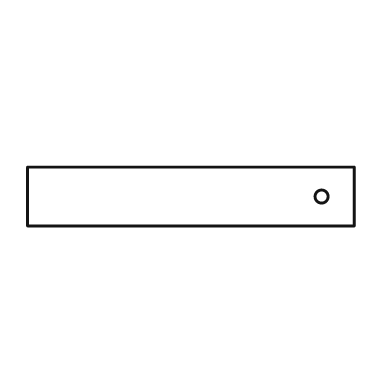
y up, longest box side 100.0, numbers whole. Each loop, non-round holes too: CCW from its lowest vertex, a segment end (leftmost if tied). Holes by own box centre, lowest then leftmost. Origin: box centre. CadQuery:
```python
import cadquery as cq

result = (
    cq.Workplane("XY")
    .moveTo(-50.0, -9.0)
    .lineTo(50.0, -9.0)
    .lineTo(50.0, 9.0)
    .lineTo(-50.0, 9.0)
    .close()
    .moveTo(40.0, 0.0)
    .circle(2.0)
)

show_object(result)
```